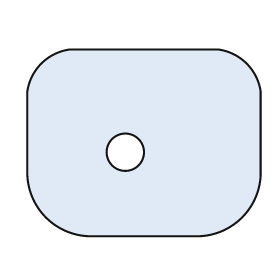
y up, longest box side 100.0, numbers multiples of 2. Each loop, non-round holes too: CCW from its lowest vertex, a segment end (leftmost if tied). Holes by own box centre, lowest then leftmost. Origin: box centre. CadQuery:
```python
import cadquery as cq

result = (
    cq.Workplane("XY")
    .moveTo(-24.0, -40.0)
    .lineTo(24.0, -40.0)
    .threePointArc((42.0, -32.0), (50.0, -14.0))
    .lineTo(50.0, 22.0)
    .threePointArc((44.0, 34.0), (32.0, 40.0))
    .lineTo(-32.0, 40.0)
    .threePointArc((-44.0, 34.0), (-50.0, 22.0))
    .lineTo(-50.0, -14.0)
    .threePointArc((-42.0, -32.0), (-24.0, -40.0))
    .close()
    .moveTo(-8.0, -4.0)
    .circle(8.0)
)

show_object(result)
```